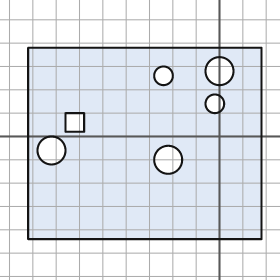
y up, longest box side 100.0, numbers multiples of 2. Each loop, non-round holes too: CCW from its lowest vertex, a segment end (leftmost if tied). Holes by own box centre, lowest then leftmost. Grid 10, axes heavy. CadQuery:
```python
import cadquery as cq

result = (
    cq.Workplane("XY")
    .moveTo(-82.0, -44.0)
    .lineTo(18.0, -44.0)
    .lineTo(18.0, 38.0)
    .lineTo(-82.0, 38.0)
    .close()
    .moveTo(-22.0, -10.0)
    .circle(6.0)
    .moveTo(-72.0, -6.0)
    .circle(6.0)
    .moveTo(-66.0, 2.0)
    .lineTo(-58.0, 2.0)
    .lineTo(-58.0, 10.0)
    .lineTo(-66.0, 10.0)
    .close()
    .moveTo(-2.0, 14.0)
    .circle(4.0)
    .moveTo(-24.0, 26.0)
    .circle(4.0)
    .moveTo(0.0, 28.0)
    .circle(6.0)
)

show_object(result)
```